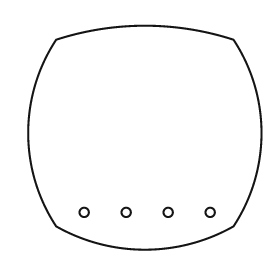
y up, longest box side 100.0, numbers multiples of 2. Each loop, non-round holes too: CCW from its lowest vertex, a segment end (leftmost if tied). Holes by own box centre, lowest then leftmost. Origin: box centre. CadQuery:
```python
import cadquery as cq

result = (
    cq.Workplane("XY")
    .moveTo(-38.0, -38.0)
    .threePointArc((0.0, -48.0), (38.0, -38.0))
    .threePointArc((50.0, 2.0), (38.0, 42.0))
    .threePointArc((0.0, 48.0), (-38.0, 42.0))
    .threePointArc((-50.0, 2.0), (-38.0, -38.0))
    .close()
    .moveTo(-26.0, -32.0)
    .circle(2.0)
    .moveTo(-8.0, -32.0)
    .circle(2.0)
    .moveTo(10.0, -32.0)
    .circle(2.0)
    .moveTo(28.0, -32.0)
    .circle(2.0)
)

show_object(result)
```